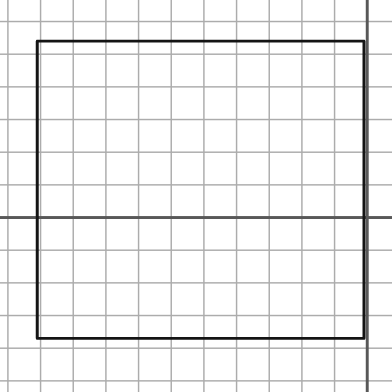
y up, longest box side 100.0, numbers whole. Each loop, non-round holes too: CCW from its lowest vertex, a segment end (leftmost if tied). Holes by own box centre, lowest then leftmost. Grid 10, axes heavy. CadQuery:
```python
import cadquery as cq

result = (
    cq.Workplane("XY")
    .moveTo(-101.0, -37.0)
    .lineTo(-1.0, -37.0)
    .lineTo(-1.0, 54.0)
    .lineTo(-101.0, 54.0)
    .close()
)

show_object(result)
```